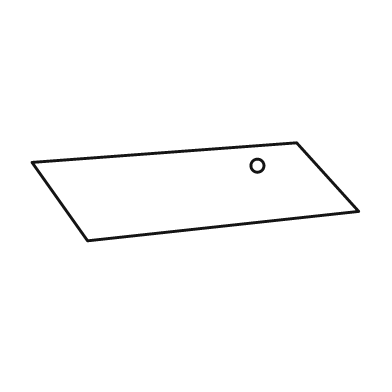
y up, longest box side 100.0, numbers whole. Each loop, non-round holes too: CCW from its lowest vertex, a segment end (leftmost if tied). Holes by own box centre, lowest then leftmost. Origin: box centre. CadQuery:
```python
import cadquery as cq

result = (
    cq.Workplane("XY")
    .moveTo(-33.0, -15.0)
    .lineTo(50.0, -6.0)
    .lineTo(31.0, 15.0)
    .lineTo(-50.0, 9.0)
    .close()
    .moveTo(19.0, 8.0)
    .circle(2.0)
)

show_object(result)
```